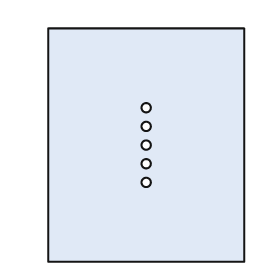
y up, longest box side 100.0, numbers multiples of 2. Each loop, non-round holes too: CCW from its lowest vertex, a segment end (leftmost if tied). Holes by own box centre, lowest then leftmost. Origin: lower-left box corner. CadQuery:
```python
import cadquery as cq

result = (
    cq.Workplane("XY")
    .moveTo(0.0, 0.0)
    .lineTo(84.0, 0.0)
    .lineTo(84.0, 100.0)
    .lineTo(0.0, 100.0)
    .close()
    .moveTo(42.0, 34.0)
    .circle(2.0)
    .moveTo(42.0, 42.0)
    .circle(2.0)
    .moveTo(42.0, 50.0)
    .circle(2.0)
    .moveTo(42.0, 58.0)
    .circle(2.0)
    .moveTo(42.0, 66.0)
    .circle(2.0)
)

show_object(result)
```